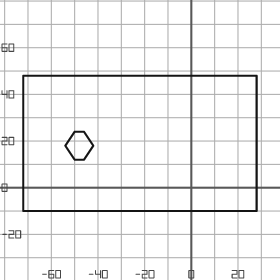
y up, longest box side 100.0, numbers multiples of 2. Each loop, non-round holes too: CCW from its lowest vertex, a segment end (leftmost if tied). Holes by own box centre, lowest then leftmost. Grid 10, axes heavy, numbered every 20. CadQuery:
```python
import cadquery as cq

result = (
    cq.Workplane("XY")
    .moveTo(-72.0, -10.0)
    .lineTo(28.0, -10.0)
    .lineTo(28.0, 48.0)
    .lineTo(-72.0, 48.0)
    .close()
    .moveTo(-50.0, 12.0)
    .lineTo(-46.0, 12.0)
    .lineTo(-42.0, 18.0)
    .lineTo(-46.0, 24.0)
    .lineTo(-50.0, 24.0)
    .lineTo(-54.0, 18.0)
    .close()
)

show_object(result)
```